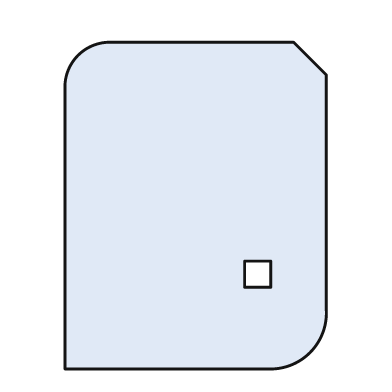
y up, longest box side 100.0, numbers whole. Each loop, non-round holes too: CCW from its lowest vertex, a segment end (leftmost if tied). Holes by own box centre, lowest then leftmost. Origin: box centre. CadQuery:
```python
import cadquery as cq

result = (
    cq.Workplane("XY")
    .moveTo(-40.0, -50.0)
    .lineTo(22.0, -50.0)
    .threePointArc((35.0, -45.0), (40.0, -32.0))
    .lineTo(40.0, 40.0)
    .lineTo(30.0, 50.0)
    .lineTo(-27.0, 50.0)
    .threePointArc((-36.0, 46.0), (-40.0, 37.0))
    .close()
    .moveTo(15.0, -25.0)
    .lineTo(23.0, -25.0)
    .lineTo(23.0, -17.0)
    .lineTo(15.0, -17.0)
    .close()
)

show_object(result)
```